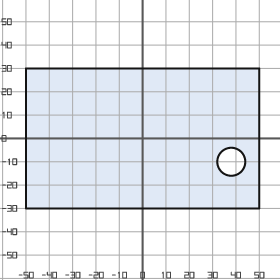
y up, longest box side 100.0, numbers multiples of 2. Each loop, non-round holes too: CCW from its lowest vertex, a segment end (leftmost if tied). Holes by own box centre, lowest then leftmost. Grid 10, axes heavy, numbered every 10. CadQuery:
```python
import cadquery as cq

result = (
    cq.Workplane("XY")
    .moveTo(-50.0, -30.0)
    .lineTo(50.0, -30.0)
    .lineTo(50.0, 30.0)
    .lineTo(-50.0, 30.0)
    .close()
    .moveTo(38.0, -10.0)
    .circle(6.0)
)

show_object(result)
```